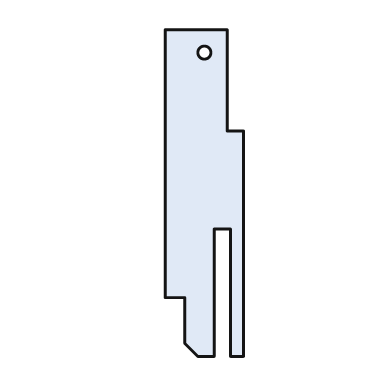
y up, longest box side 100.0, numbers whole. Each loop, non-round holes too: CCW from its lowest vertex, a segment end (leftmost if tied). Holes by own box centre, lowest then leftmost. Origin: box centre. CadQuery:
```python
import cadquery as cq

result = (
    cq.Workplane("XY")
    .moveTo(-2.0, -50.0)
    .lineTo(3.0, -50.0)
    .lineTo(3.0, -11.0)
    .lineTo(8.0, -11.0)
    .lineTo(8.0, -50.0)
    .lineTo(12.0, -50.0)
    .lineTo(12.0, 19.0)
    .lineTo(7.0, 19.0)
    .lineTo(7.0, 50.0)
    .lineTo(-12.0, 50.0)
    .lineTo(-12.0, -32.0)
    .lineTo(-6.0, -32.0)
    .lineTo(-6.0, -46.0)
    .close()
    .moveTo(0.0, 43.0)
    .circle(2.0)
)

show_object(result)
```